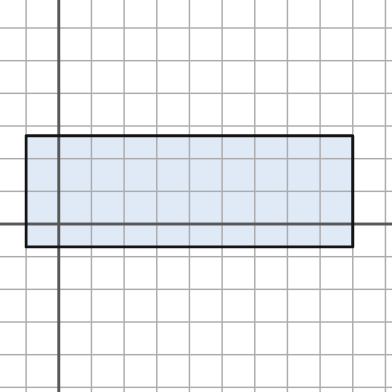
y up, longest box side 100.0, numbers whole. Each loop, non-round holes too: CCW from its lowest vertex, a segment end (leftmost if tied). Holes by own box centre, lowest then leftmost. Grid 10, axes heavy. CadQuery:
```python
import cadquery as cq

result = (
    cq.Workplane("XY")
    .moveTo(-10.0, -7.0)
    .lineTo(90.0, -7.0)
    .lineTo(90.0, 27.0)
    .lineTo(-10.0, 27.0)
    .close()
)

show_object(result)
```